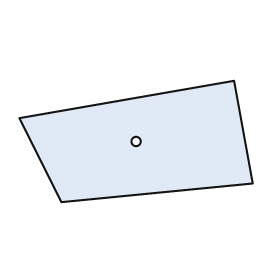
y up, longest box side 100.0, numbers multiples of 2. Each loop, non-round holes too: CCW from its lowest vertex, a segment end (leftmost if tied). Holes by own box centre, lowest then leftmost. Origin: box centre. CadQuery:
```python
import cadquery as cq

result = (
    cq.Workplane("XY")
    .moveTo(-32.0, -26.0)
    .lineTo(50.0, -18.0)
    .lineTo(42.0, 26.0)
    .lineTo(-50.0, 10.0)
    .close()
    .moveTo(0.0, 0.0)
    .circle(2.0)
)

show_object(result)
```